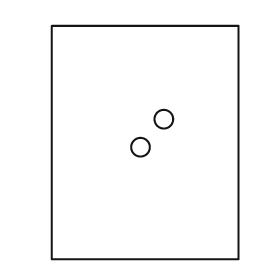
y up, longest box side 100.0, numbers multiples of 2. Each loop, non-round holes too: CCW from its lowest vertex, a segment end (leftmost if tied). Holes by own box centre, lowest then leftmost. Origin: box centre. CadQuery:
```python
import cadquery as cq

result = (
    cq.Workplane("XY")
    .moveTo(-40.0, -50.0)
    .lineTo(40.0, -50.0)
    .lineTo(40.0, 50.0)
    .lineTo(-40.0, 50.0)
    .close()
    .moveTo(-2.0, -2.0)
    .circle(4.0)
    .moveTo(8.0, 10.0)
    .circle(4.0)
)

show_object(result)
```